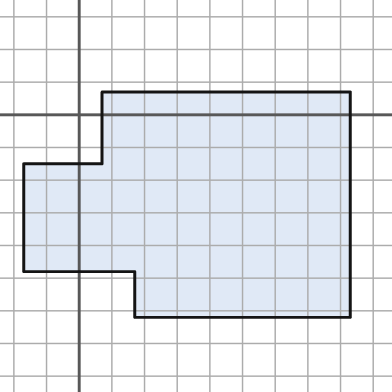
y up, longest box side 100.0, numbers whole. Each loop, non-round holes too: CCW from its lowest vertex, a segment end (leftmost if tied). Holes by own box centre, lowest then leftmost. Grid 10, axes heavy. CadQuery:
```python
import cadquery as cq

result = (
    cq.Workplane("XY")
    .moveTo(17.0, -62.0)
    .lineTo(83.0, -62.0)
    .lineTo(83.0, 7.0)
    .lineTo(7.0, 7.0)
    .lineTo(7.0, -15.0)
    .lineTo(-17.0, -15.0)
    .lineTo(-17.0, -48.0)
    .lineTo(17.0, -48.0)
    .close()
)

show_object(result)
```